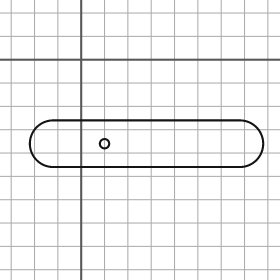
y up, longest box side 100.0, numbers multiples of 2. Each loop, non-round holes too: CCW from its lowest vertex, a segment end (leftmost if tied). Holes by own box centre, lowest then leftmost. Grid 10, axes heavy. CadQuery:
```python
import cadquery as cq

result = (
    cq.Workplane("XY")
    .moveTo(-12.0, -46.0)
    .lineTo(68.0, -46.0)
    .threePointArc((78.0, -36.0), (68.0, -26.0))
    .lineTo(-12.0, -26.0)
    .threePointArc((-22.0, -36.0), (-12.0, -46.0))
    .close()
    .moveTo(10.0, -36.0)
    .circle(2.0)
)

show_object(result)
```